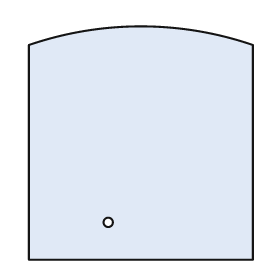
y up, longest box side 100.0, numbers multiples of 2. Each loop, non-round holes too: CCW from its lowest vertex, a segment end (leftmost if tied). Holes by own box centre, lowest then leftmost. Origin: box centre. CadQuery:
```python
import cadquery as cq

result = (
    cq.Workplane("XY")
    .moveTo(-48.0, -50.0)
    .lineTo(48.0, -50.0)
    .lineTo(48.0, 42.0)
    .threePointArc((0.0, 50.0), (-48.0, 42.0))
    .close()
    .moveTo(-14.0, -34.0)
    .circle(2.0)
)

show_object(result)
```